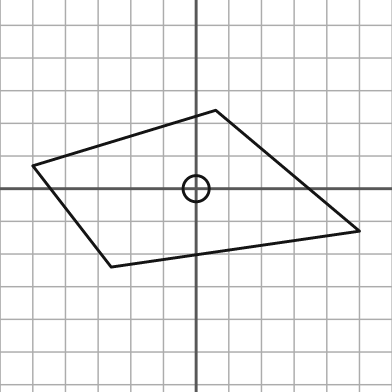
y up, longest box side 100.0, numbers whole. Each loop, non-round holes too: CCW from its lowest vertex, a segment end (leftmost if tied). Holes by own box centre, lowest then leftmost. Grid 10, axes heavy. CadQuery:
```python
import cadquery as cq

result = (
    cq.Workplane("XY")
    .moveTo(-26.0, -24.0)
    .lineTo(50.0, -13.0)
    .lineTo(6.0, 24.0)
    .lineTo(-50.0, 7.0)
    .close()
    .moveTo(0.0, 0.0)
    .circle(4.0)
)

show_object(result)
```